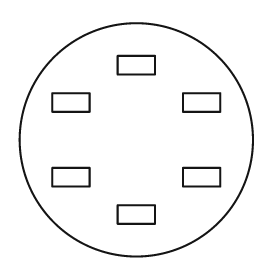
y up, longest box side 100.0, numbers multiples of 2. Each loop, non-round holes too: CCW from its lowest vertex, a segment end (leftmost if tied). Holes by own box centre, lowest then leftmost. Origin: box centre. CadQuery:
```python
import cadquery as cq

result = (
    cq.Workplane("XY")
    .moveTo(0.0, 0.0)
    .circle(50.0)
    .moveTo(-8.0, -36.0)
    .lineTo(8.0, -36.0)
    .lineTo(8.0, -28.0)
    .lineTo(-8.0, -28.0)
    .close()
    .moveTo(-36.0, -20.0)
    .lineTo(-20.0, -20.0)
    .lineTo(-20.0, -12.0)
    .lineTo(-36.0, -12.0)
    .close()
    .moveTo(20.0, -20.0)
    .lineTo(36.0, -20.0)
    .lineTo(36.0, -12.0)
    .lineTo(20.0, -12.0)
    .close()
    .moveTo(-36.0, 12.0)
    .lineTo(-20.0, 12.0)
    .lineTo(-20.0, 20.0)
    .lineTo(-36.0, 20.0)
    .close()
    .moveTo(20.0, 12.0)
    .lineTo(36.0, 12.0)
    .lineTo(36.0, 20.0)
    .lineTo(20.0, 20.0)
    .close()
    .moveTo(-8.0, 28.0)
    .lineTo(8.0, 28.0)
    .lineTo(8.0, 36.0)
    .lineTo(-8.0, 36.0)
    .close()
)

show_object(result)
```